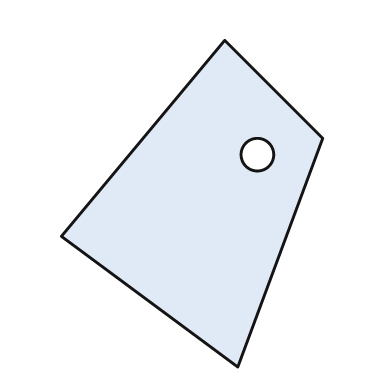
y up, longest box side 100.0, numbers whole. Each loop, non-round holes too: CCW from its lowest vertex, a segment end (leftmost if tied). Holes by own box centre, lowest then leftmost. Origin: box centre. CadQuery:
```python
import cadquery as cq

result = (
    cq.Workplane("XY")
    .moveTo(14.0, -50.0)
    .lineTo(40.0, 20.0)
    .lineTo(10.0, 50.0)
    .lineTo(-40.0, -10.0)
    .close()
    .moveTo(20.0, 15.0)
    .circle(5.0)
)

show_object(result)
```